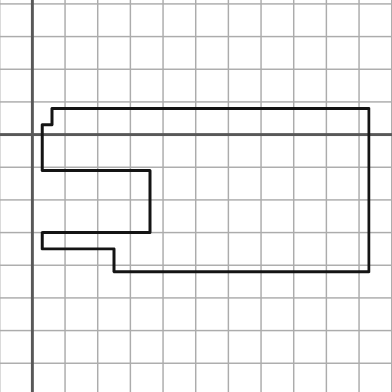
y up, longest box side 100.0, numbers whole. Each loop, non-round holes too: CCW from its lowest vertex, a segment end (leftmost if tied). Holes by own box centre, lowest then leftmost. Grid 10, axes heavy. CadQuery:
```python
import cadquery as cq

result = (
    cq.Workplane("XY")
    .moveTo(25.0, -42.0)
    .lineTo(103.0, -42.0)
    .lineTo(103.0, 8.0)
    .lineTo(6.0, 8.0)
    .lineTo(6.0, 3.0)
    .lineTo(3.0, 3.0)
    .lineTo(3.0, -11.0)
    .lineTo(36.0, -11.0)
    .lineTo(36.0, -30.0)
    .lineTo(3.0, -30.0)
    .lineTo(3.0, -35.0)
    .lineTo(25.0, -35.0)
    .close()
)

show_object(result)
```